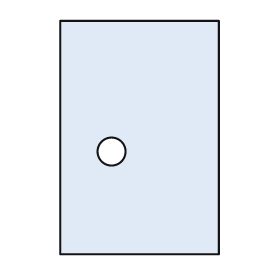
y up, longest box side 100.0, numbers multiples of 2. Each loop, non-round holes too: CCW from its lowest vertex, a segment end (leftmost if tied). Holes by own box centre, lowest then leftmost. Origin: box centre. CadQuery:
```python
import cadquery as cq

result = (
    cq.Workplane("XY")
    .moveTo(-34.0, -50.0)
    .lineTo(34.0, -50.0)
    .lineTo(34.0, 50.0)
    .lineTo(-34.0, 50.0)
    .close()
    .moveTo(-12.0, -6.0)
    .circle(6.0)
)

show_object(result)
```